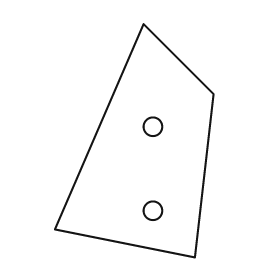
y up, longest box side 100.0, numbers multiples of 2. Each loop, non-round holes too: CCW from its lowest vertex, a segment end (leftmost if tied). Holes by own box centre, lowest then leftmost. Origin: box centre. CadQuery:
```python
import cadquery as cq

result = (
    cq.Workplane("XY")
    .moveTo(26.0, -50.0)
    .lineTo(34.0, 20.0)
    .lineTo(4.0, 50.0)
    .lineTo(-34.0, -38.0)
    .close()
    .moveTo(8.0, -30.0)
    .circle(4.0)
    .moveTo(8.0, 6.0)
    .circle(4.0)
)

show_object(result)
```